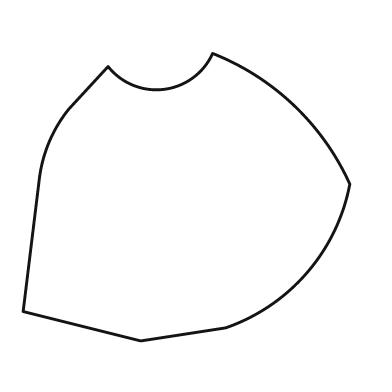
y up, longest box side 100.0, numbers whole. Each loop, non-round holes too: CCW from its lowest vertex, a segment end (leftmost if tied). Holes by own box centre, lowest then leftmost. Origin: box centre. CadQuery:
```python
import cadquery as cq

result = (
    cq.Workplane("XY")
    .moveTo(-14.0, -44.0)
    .lineTo(12.0, -40.0)
    .threePointArc((37.0, -23.0), (50.0, 4.0))
    .threePointArc((33.0, 28.0), (8.0, 44.0))
    .threePointArc((-7.0, 33.0), (-24.0, 40.0))
    .lineTo(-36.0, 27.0)
    .threePointArc((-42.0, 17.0), (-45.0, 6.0))
    .lineTo(-50.0, -35.0)
    .close()
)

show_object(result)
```